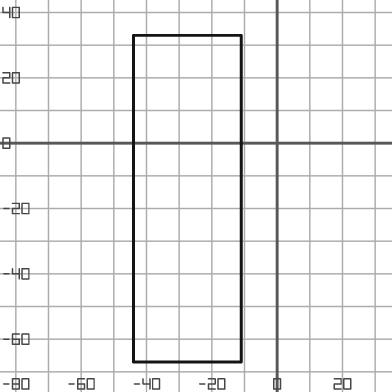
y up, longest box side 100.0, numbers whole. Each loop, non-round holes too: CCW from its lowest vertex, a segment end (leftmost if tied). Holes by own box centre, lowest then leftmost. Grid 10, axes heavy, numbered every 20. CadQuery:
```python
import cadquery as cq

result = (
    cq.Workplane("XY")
    .moveTo(-44.0, -67.0)
    .lineTo(-11.0, -67.0)
    .lineTo(-11.0, 33.0)
    .lineTo(-44.0, 33.0)
    .close()
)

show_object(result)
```